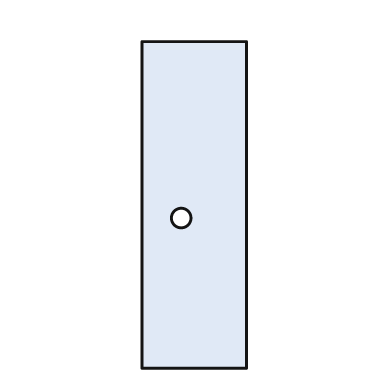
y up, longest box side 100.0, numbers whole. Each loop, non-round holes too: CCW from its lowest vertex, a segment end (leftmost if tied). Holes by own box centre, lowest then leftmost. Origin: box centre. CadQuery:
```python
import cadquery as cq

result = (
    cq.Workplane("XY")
    .moveTo(-16.0, -50.0)
    .lineTo(16.0, -50.0)
    .lineTo(16.0, 50.0)
    .lineTo(-16.0, 50.0)
    .close()
    .moveTo(-4.0, -4.0)
    .circle(3.0)
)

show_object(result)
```